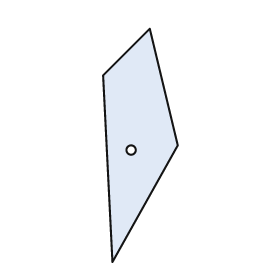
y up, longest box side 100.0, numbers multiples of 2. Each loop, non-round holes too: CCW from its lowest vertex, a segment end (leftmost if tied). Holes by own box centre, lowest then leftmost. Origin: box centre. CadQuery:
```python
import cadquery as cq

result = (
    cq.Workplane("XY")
    .moveTo(-12.0, -50.0)
    .lineTo(16.0, 0.0)
    .lineTo(4.0, 50.0)
    .lineTo(-16.0, 30.0)
    .close()
    .moveTo(-4.0, -2.0)
    .circle(2.0)
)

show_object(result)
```